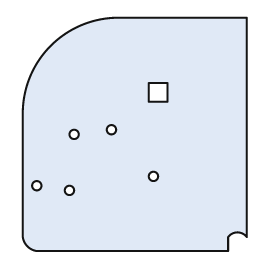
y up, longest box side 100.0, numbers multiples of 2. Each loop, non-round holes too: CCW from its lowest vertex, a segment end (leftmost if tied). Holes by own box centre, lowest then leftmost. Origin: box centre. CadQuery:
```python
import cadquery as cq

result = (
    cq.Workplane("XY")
    .moveTo(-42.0, -50.0)
    .lineTo(40.0, -50.0)
    .lineTo(40.0, -44.0)
    .threePointArc((44.0, -42.0), (48.0, -44.0))
    .lineTo(48.0, 50.0)
    .lineTo(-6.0, 50.0)
    .threePointArc((-36.0, 38.0), (-48.0, 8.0))
    .lineTo(-48.0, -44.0)
    .threePointArc((-46.0, -48.0), (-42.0, -50.0))
    .close()
    .moveTo(-28.0, -24.0)
    .circle(2.0)
    .moveTo(-42.0, -22.0)
    .circle(2.0)
    .moveTo(8.0, -18.0)
    .circle(2.0)
    .moveTo(-26.0, 0.0)
    .circle(2.0)
    .moveTo(-10.0, 2.0)
    .circle(2.0)
    .moveTo(6.0, 14.0)
    .lineTo(14.0, 14.0)
    .lineTo(14.0, 22.0)
    .lineTo(6.0, 22.0)
    .close()
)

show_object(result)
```